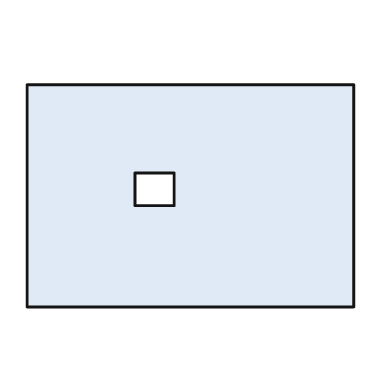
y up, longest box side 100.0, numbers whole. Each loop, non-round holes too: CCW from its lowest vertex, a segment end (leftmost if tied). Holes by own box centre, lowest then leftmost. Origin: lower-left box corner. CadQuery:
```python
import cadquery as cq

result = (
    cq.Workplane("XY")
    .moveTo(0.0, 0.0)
    .lineTo(100.0, 0.0)
    .lineTo(100.0, 68.0)
    .lineTo(0.0, 68.0)
    .close()
    .moveTo(33.0, 31.0)
    .lineTo(45.0, 31.0)
    .lineTo(45.0, 41.0)
    .lineTo(33.0, 41.0)
    .close()
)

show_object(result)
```